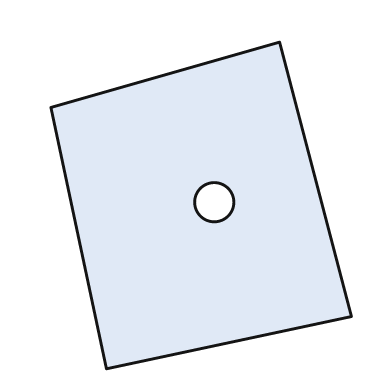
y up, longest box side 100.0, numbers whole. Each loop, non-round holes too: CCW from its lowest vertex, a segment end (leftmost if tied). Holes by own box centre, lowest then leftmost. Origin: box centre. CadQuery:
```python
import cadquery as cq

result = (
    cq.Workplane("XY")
    .moveTo(-29.0, -50.0)
    .lineTo(46.0, -34.0)
    .lineTo(24.0, 50.0)
    .lineTo(-46.0, 30.0)
    .close()
    .moveTo(4.0, 1.0)
    .circle(6.0)
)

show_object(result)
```